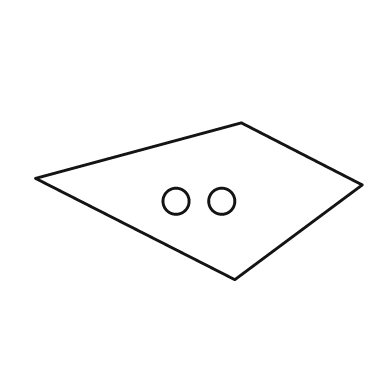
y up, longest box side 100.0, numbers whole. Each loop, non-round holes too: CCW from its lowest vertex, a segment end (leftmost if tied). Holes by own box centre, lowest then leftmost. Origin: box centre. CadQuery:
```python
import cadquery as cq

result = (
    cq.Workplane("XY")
    .moveTo(11.0, -24.0)
    .lineTo(50.0, 5.0)
    .lineTo(13.0, 24.0)
    .lineTo(-50.0, 7.0)
    .close()
    .moveTo(-7.0, 0.0)
    .circle(4.0)
    .moveTo(7.0, 0.0)
    .circle(4.0)
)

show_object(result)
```